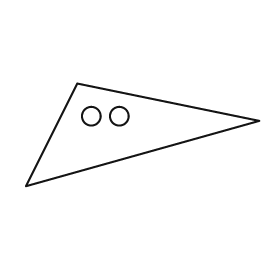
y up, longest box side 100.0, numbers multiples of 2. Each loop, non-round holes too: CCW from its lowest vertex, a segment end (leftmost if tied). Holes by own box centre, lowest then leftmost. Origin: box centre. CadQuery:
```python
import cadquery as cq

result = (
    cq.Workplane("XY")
    .moveTo(-50.0, -22.0)
    .lineTo(50.0, 6.0)
    .lineTo(-28.0, 22.0)
    .close()
    .moveTo(-22.0, 8.0)
    .circle(4.0)
    .moveTo(-10.0, 8.0)
    .circle(4.0)
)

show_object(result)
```